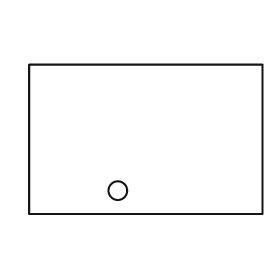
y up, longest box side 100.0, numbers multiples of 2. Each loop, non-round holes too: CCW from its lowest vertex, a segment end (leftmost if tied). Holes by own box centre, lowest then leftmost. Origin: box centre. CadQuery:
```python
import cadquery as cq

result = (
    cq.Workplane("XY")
    .moveTo(-50.0, -32.0)
    .lineTo(50.0, -32.0)
    .lineTo(50.0, 32.0)
    .lineTo(-50.0, 32.0)
    .close()
    .moveTo(-12.0, -22.0)
    .circle(4.0)
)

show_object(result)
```